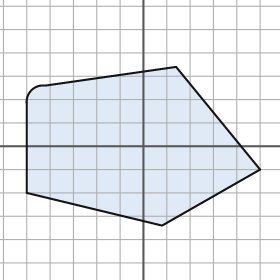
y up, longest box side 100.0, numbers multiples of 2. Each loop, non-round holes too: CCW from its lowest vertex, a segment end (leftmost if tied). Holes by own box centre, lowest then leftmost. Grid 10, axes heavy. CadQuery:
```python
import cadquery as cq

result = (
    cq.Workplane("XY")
    .moveTo(8.0, -34.0)
    .lineTo(50.0, -10.0)
    .lineTo(14.0, 34.0)
    .lineTo(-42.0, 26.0)
    .threePointArc((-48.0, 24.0), (-50.0, 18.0))
    .lineTo(-50.0, -20.0)
    .close()
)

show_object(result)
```